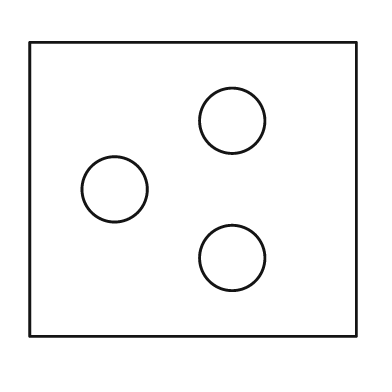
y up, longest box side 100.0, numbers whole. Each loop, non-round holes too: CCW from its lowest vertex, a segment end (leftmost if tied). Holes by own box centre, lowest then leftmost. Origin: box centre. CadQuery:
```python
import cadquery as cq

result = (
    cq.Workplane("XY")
    .moveTo(-50.0, -45.0)
    .lineTo(50.0, -45.0)
    .lineTo(50.0, 45.0)
    .lineTo(-50.0, 45.0)
    .close()
    .moveTo(12.0, -21.0)
    .circle(10.0)
    .moveTo(-24.0, 0.0)
    .circle(10.0)
    .moveTo(12.0, 21.0)
    .circle(10.0)
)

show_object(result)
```